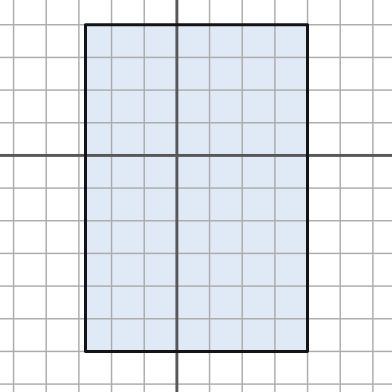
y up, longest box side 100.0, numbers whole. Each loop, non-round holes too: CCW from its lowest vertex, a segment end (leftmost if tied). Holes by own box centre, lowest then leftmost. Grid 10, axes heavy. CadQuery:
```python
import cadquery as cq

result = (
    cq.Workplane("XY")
    .moveTo(-28.0, -60.0)
    .lineTo(40.0, -60.0)
    .lineTo(40.0, 40.0)
    .lineTo(-28.0, 40.0)
    .close()
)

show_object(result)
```